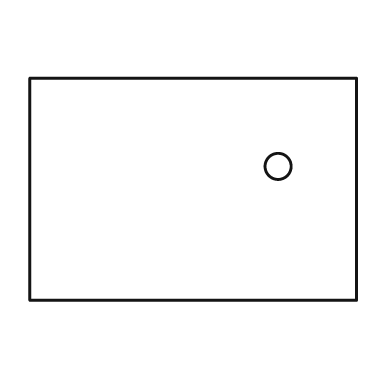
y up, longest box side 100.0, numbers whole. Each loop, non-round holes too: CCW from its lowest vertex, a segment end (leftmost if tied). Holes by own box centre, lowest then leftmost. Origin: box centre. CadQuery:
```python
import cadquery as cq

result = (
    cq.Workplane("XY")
    .moveTo(-50.0, -34.0)
    .lineTo(50.0, -34.0)
    .lineTo(50.0, 34.0)
    .lineTo(-50.0, 34.0)
    .close()
    .moveTo(26.0, 7.0)
    .circle(4.0)
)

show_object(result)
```